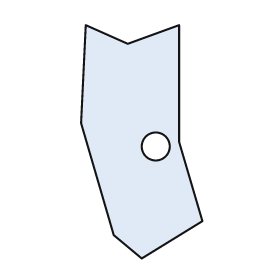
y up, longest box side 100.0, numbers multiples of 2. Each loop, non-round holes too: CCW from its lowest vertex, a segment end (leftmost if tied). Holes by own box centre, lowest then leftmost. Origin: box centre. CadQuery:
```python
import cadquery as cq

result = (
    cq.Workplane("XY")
    .moveTo(0.0, -50.0)
    .lineTo(26.0, -34.0)
    .lineTo(16.0, 0.0)
    .lineTo(16.0, 50.0)
    .lineTo(-6.0, 42.0)
    .lineTo(-24.0, 50.0)
    .lineTo(-26.0, 8.0)
    .lineTo(-12.0, -40.0)
    .close()
    .moveTo(6.0, -2.0)
    .circle(6.0)
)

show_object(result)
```